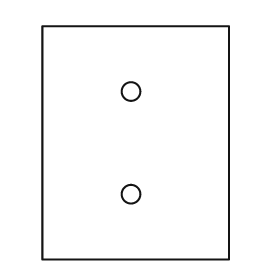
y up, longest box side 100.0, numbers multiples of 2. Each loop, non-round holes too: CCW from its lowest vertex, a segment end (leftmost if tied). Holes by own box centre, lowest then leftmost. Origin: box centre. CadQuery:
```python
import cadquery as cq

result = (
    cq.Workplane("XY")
    .moveTo(-40.0, -50.0)
    .lineTo(40.0, -50.0)
    .lineTo(40.0, 50.0)
    .lineTo(-40.0, 50.0)
    .close()
    .moveTo(-2.0, -22.0)
    .circle(4.0)
    .moveTo(-2.0, 22.0)
    .circle(4.0)
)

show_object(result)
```